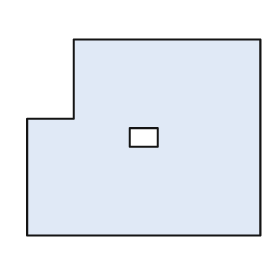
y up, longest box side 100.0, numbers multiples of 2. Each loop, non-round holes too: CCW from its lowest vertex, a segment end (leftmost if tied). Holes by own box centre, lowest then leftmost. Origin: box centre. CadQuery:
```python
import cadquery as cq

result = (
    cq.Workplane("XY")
    .moveTo(-50.0, -42.0)
    .lineTo(50.0, -42.0)
    .lineTo(50.0, 42.0)
    .lineTo(-30.0, 42.0)
    .lineTo(-30.0, 8.0)
    .lineTo(-50.0, 8.0)
    .close()
    .moveTo(-6.0, -4.0)
    .lineTo(6.0, -4.0)
    .lineTo(6.0, 4.0)
    .lineTo(-6.0, 4.0)
    .close()
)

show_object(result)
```